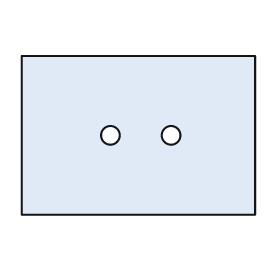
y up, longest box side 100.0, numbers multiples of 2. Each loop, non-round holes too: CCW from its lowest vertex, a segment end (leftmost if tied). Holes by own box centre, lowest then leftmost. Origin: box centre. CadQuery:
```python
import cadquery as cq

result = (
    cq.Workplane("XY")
    .moveTo(-50.0, -34.0)
    .lineTo(50.0, -34.0)
    .lineTo(50.0, 34.0)
    .lineTo(-50.0, 34.0)
    .close()
    .moveTo(-12.0, 0.0)
    .circle(4.0)
    .moveTo(14.0, 0.0)
    .circle(4.0)
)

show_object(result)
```